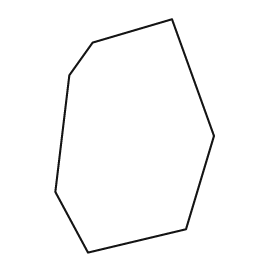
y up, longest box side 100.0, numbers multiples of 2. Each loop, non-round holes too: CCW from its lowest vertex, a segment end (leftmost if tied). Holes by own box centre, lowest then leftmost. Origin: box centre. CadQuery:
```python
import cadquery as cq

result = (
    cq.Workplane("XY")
    .moveTo(-20.0, -50.0)
    .lineTo(22.0, -40.0)
    .lineTo(34.0, 0.0)
    .lineTo(16.0, 50.0)
    .lineTo(-18.0, 40.0)
    .lineTo(-28.0, 26.0)
    .lineTo(-34.0, -24.0)
    .close()
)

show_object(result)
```